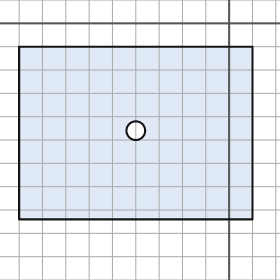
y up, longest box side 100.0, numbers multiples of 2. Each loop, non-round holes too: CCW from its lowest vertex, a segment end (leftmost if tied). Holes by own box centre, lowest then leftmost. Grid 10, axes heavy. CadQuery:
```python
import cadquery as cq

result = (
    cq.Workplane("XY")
    .moveTo(-90.0, -84.0)
    .lineTo(10.0, -84.0)
    .lineTo(10.0, -10.0)
    .lineTo(-90.0, -10.0)
    .close()
    .moveTo(-40.0, -46.0)
    .circle(4.0)
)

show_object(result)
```